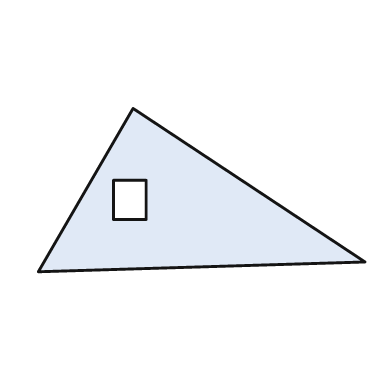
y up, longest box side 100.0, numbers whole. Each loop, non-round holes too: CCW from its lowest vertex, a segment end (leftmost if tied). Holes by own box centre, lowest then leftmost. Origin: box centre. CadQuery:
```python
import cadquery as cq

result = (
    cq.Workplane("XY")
    .moveTo(-50.0, -25.0)
    .lineTo(50.0, -22.0)
    .lineTo(-21.0, 25.0)
    .close()
    .moveTo(-27.0, -9.0)
    .lineTo(-17.0, -9.0)
    .lineTo(-17.0, 3.0)
    .lineTo(-27.0, 3.0)
    .close()
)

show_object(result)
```